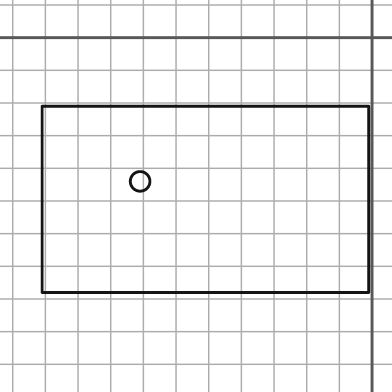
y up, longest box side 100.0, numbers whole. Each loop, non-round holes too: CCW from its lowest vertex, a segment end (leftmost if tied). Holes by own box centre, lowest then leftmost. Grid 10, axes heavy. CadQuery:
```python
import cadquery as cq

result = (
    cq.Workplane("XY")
    .moveTo(-101.0, -78.0)
    .lineTo(-1.0, -78.0)
    .lineTo(-1.0, -21.0)
    .lineTo(-101.0, -21.0)
    .close()
    .moveTo(-71.0, -44.0)
    .circle(3.0)
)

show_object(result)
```